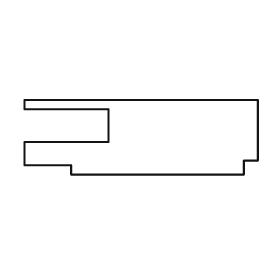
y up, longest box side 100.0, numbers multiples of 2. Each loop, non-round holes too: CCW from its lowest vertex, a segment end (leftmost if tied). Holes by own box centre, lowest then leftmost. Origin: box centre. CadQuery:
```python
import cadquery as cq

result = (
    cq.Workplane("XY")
    .moveTo(-30.0, -16.0)
    .lineTo(44.0, -16.0)
    .lineTo(44.0, -10.0)
    .lineTo(50.0, -10.0)
    .lineTo(50.0, 16.0)
    .lineTo(-50.0, 16.0)
    .lineTo(-50.0, 12.0)
    .lineTo(-14.0, 12.0)
    .lineTo(-14.0, -2.0)
    .lineTo(-50.0, -2.0)
    .lineTo(-50.0, -12.0)
    .lineTo(-30.0, -12.0)
    .close()
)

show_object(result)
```